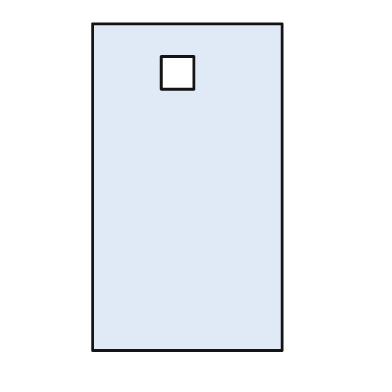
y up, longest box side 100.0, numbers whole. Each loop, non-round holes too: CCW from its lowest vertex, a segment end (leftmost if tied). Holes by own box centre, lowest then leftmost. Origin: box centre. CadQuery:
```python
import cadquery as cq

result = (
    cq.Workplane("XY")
    .moveTo(-29.0, -50.0)
    .lineTo(29.0, -50.0)
    .lineTo(29.0, 50.0)
    .lineTo(-29.0, 50.0)
    .close()
    .moveTo(-8.0, 30.0)
    .lineTo(2.0, 30.0)
    .lineTo(2.0, 40.0)
    .lineTo(-8.0, 40.0)
    .close()
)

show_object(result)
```